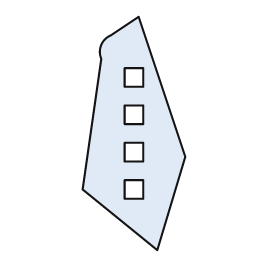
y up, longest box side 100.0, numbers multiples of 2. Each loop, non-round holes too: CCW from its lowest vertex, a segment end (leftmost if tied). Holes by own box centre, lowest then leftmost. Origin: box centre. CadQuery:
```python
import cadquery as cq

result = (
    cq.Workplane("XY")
    .moveTo(10.0, -50.0)
    .lineTo(22.0, -10.0)
    .lineTo(2.0, 50.0)
    .lineTo(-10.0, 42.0)
    .threePointArc((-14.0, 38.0), (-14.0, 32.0))
    .lineTo(-22.0, -24.0)
    .close()
    .moveTo(-4.0, -28.0)
    .lineTo(4.0, -28.0)
    .lineTo(4.0, -20.0)
    .lineTo(-4.0, -20.0)
    .close()
    .moveTo(-4.0, -12.0)
    .lineTo(4.0, -12.0)
    .lineTo(4.0, -4.0)
    .lineTo(-4.0, -4.0)
    .close()
    .moveTo(-4.0, 4.0)
    .lineTo(4.0, 4.0)
    .lineTo(4.0, 12.0)
    .lineTo(-4.0, 12.0)
    .close()
    .moveTo(-4.0, 20.0)
    .lineTo(4.0, 20.0)
    .lineTo(4.0, 28.0)
    .lineTo(-4.0, 28.0)
    .close()
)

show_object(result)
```